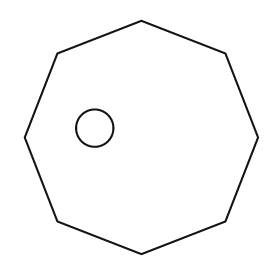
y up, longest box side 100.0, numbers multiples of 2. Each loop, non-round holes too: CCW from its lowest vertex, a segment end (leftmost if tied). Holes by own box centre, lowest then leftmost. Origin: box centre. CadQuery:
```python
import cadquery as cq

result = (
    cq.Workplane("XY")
    .moveTo(0.0, -50.0)
    .lineTo(36.0, -36.0)
    .lineTo(50.0, 0.0)
    .lineTo(36.0, 36.0)
    .lineTo(0.0, 50.0)
    .lineTo(-36.0, 36.0)
    .lineTo(-50.0, 0.0)
    .lineTo(-36.0, -36.0)
    .close()
    .moveTo(-20.0, 4.0)
    .circle(8.0)
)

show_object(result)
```